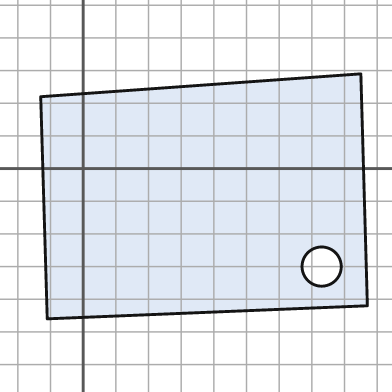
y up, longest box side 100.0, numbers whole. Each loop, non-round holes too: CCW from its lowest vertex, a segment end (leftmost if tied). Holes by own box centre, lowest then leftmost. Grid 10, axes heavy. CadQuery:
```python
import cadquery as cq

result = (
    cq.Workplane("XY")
    .moveTo(-11.0, -46.0)
    .lineTo(87.0, -42.0)
    .lineTo(85.0, 29.0)
    .lineTo(-13.0, 22.0)
    .close()
    .moveTo(73.0, -30.0)
    .circle(6.0)
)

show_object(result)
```